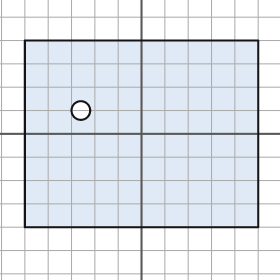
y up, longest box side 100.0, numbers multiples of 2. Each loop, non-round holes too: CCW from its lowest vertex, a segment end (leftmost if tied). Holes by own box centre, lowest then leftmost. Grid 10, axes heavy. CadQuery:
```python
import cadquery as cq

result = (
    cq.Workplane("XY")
    .moveTo(-50.0, -40.0)
    .lineTo(50.0, -40.0)
    .lineTo(50.0, 40.0)
    .lineTo(-50.0, 40.0)
    .close()
    .moveTo(-26.0, 10.0)
    .circle(4.0)
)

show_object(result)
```